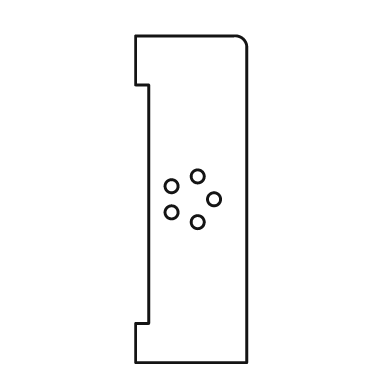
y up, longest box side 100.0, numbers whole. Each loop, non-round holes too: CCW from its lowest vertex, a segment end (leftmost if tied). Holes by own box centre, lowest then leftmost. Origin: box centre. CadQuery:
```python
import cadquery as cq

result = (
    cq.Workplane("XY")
    .moveTo(-17.0, -50.0)
    .lineTo(17.0, -50.0)
    .lineTo(17.0, 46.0)
    .threePointArc((16.0, 49.0), (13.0, 50.0))
    .lineTo(-17.0, 50.0)
    .lineTo(-17.0, 35.0)
    .lineTo(-13.0, 35.0)
    .lineTo(-13.0, -38.0)
    .lineTo(-17.0, -38.0)
    .close()
    .moveTo(2.0, -7.0)
    .circle(2.0)
    .moveTo(-6.0, -4.0)
    .circle(2.0)
    .moveTo(7.0, 0.0)
    .circle(2.0)
    .moveTo(-6.0, 4.0)
    .circle(2.0)
    .moveTo(2.0, 7.0)
    .circle(2.0)
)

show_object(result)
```